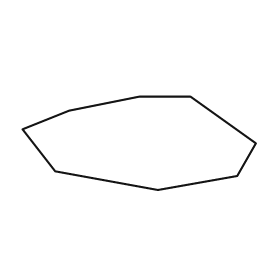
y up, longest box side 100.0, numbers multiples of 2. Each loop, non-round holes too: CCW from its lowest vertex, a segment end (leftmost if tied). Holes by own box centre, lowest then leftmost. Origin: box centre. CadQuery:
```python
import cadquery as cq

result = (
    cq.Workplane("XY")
    .moveTo(8.0, -20.0)
    .lineTo(42.0, -14.0)
    .lineTo(50.0, 0.0)
    .lineTo(22.0, 20.0)
    .lineTo(0.0, 20.0)
    .lineTo(-30.0, 14.0)
    .lineTo(-50.0, 6.0)
    .lineTo(-36.0, -12.0)
    .close()
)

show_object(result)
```